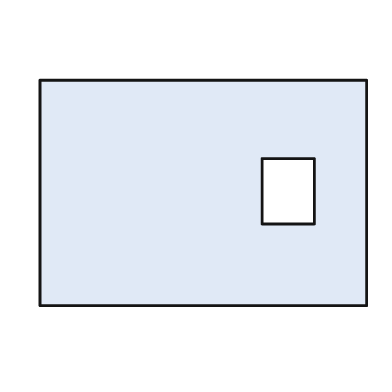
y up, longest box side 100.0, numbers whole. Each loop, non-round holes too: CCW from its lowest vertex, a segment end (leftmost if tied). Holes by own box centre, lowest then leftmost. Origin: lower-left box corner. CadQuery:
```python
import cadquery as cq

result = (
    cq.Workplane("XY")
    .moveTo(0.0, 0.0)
    .lineTo(100.0, 0.0)
    .lineTo(100.0, 69.0)
    .lineTo(0.0, 69.0)
    .close()
    .moveTo(68.0, 25.0)
    .lineTo(84.0, 25.0)
    .lineTo(84.0, 45.0)
    .lineTo(68.0, 45.0)
    .close()
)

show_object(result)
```